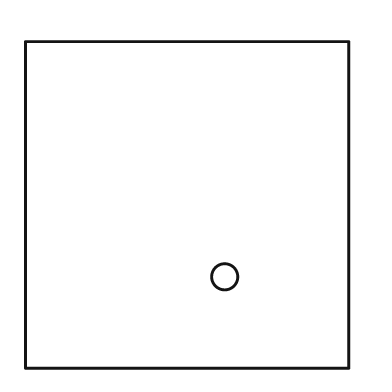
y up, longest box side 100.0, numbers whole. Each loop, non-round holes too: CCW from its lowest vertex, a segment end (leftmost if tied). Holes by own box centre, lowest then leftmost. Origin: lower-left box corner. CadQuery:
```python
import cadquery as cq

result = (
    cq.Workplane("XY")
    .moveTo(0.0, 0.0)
    .lineTo(99.0, 0.0)
    .lineTo(99.0, 100.0)
    .lineTo(0.0, 100.0)
    .close()
    .moveTo(61.0, 28.0)
    .circle(4.0)
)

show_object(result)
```